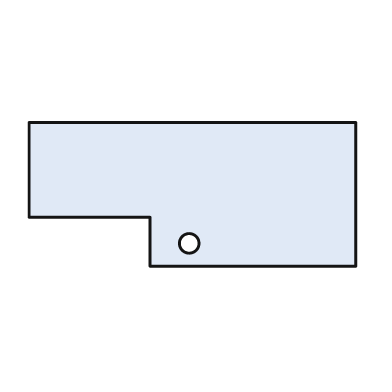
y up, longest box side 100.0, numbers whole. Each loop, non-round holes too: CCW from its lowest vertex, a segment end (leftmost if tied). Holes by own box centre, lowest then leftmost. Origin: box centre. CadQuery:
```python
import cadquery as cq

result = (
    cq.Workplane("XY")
    .moveTo(-13.0, -22.0)
    .lineTo(50.0, -22.0)
    .lineTo(50.0, 22.0)
    .lineTo(-50.0, 22.0)
    .lineTo(-50.0, -7.0)
    .lineTo(-13.0, -7.0)
    .close()
    .moveTo(-1.0, -15.0)
    .circle(3.0)
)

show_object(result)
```